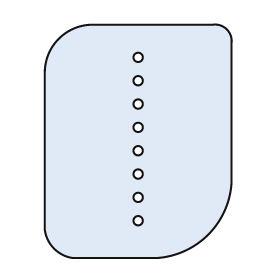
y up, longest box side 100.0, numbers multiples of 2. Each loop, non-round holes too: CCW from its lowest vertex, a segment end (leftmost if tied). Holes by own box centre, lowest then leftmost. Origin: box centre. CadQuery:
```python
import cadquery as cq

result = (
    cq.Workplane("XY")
    .moveTo(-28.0, -50.0)
    .lineTo(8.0, -50.0)
    .threePointArc((30.0, -40.0), (40.0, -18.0))
    .lineTo(40.0, 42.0)
    .threePointArc((38.0, 48.0), (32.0, 50.0))
    .lineTo(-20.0, 50.0)
    .threePointArc((-34.0, 44.0), (-40.0, 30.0))
    .lineTo(-40.0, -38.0)
    .threePointArc((-36.0, -46.0), (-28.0, -50.0))
    .close()
    .moveTo(0.0, -34.0)
    .circle(2.0)
    .moveTo(0.0, -24.0)
    .circle(2.0)
    .moveTo(0.0, -14.0)
    .circle(2.0)
    .moveTo(0.0, -4.0)
    .circle(2.0)
    .moveTo(0.0, 6.0)
    .circle(2.0)
    .moveTo(0.0, 16.0)
    .circle(2.0)
    .moveTo(0.0, 26.0)
    .circle(2.0)
    .moveTo(0.0, 36.0)
    .circle(2.0)
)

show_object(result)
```